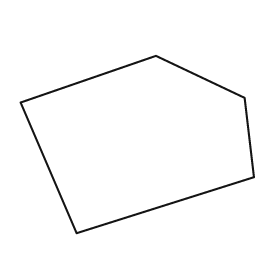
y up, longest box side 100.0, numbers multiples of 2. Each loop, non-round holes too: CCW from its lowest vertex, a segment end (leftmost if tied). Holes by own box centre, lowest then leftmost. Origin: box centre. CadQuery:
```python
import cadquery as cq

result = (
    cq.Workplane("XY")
    .moveTo(-26.0, -38.0)
    .lineTo(50.0, -14.0)
    .lineTo(46.0, 20.0)
    .lineTo(8.0, 38.0)
    .lineTo(-50.0, 18.0)
    .close()
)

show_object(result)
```